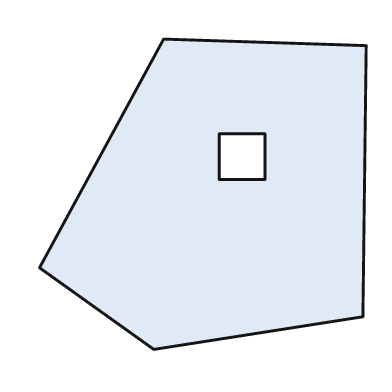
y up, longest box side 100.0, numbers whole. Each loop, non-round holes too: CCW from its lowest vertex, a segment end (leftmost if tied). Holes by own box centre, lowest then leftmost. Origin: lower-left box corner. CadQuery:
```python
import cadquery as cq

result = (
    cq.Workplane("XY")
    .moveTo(35.0, 0.0)
    .lineTo(99.0, 10.0)
    .lineTo(100.0, 93.0)
    .lineTo(38.0, 95.0)
    .lineTo(0.0, 25.0)
    .close()
    .moveTo(55.0, 52.0)
    .lineTo(69.0, 52.0)
    .lineTo(69.0, 66.0)
    .lineTo(55.0, 66.0)
    .close()
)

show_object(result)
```